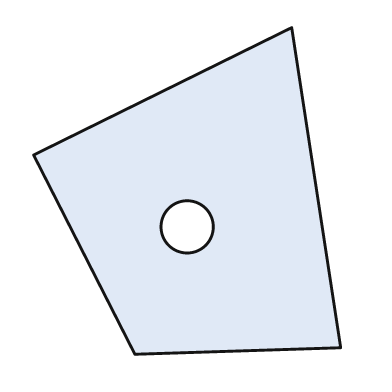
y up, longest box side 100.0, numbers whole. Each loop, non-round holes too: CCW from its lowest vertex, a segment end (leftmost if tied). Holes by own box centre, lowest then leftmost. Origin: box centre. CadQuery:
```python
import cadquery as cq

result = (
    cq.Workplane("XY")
    .moveTo(-16.0, -50.0)
    .lineTo(47.0, -48.0)
    .lineTo(32.0, 50.0)
    .lineTo(-47.0, 11.0)
    .close()
    .moveTo(0.0, -11.0)
    .circle(8.0)
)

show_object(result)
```